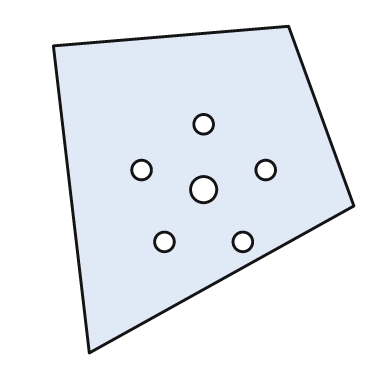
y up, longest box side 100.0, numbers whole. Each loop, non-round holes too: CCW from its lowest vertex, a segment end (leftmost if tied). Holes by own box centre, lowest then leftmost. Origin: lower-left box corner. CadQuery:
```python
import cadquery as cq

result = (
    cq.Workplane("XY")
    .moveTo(11.0, 0.0)
    .lineTo(92.0, 45.0)
    .lineTo(72.0, 100.0)
    .lineTo(0.0, 94.0)
    .close()
    .moveTo(34.0, 34.0)
    .circle(3.0)
    .moveTo(58.0, 34.0)
    .circle(3.0)
    .moveTo(46.0, 50.0)
    .circle(4.0)
    .moveTo(27.0, 56.0)
    .circle(3.0)
    .moveTo(65.0, 56.0)
    .circle(3.0)
    .moveTo(46.0, 70.0)
    .circle(3.0)
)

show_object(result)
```